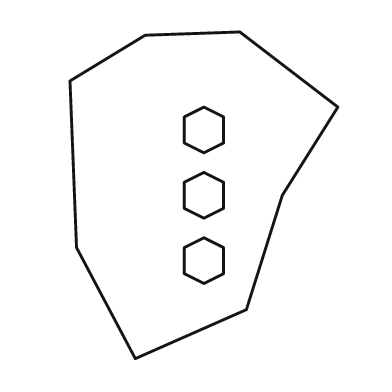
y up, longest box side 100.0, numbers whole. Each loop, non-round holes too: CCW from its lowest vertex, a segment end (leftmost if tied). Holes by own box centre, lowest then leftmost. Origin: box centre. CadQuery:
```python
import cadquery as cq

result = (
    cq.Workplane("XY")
    .moveTo(-21.0, -50.0)
    .lineTo(13.0, -35.0)
    .lineTo(24.0, 0.0)
    .lineTo(41.0, 27.0)
    .lineTo(11.0, 50.0)
    .lineTo(-18.0, 49.0)
    .lineTo(-41.0, 35.0)
    .lineTo(-39.0, -16.0)
    .close()
    .moveTo(0.0, -27.0)
    .lineTo(6.0, -24.0)
    .lineTo(6.0, -16.0)
    .lineTo(0.0, -13.0)
    .lineTo(-6.0, -16.0)
    .lineTo(-6.0, -24.0)
    .close()
    .moveTo(0.0, -7.0)
    .lineTo(6.0, -4.0)
    .lineTo(6.0, 4.0)
    .lineTo(0.0, 7.0)
    .lineTo(-6.0, 4.0)
    .lineTo(-6.0, -4.0)
    .close()
    .moveTo(0.0, 13.0)
    .lineTo(6.0, 16.0)
    .lineTo(6.0, 24.0)
    .lineTo(0.0, 27.0)
    .lineTo(-6.0, 24.0)
    .lineTo(-6.0, 16.0)
    .close()
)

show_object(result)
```